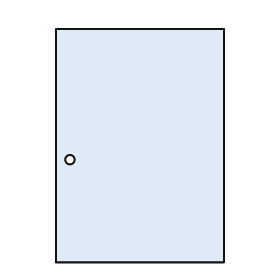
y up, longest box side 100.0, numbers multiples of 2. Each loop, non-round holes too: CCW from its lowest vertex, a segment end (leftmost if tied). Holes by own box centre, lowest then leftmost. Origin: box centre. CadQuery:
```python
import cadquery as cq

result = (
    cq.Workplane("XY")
    .moveTo(-36.0, -50.0)
    .lineTo(36.0, -50.0)
    .lineTo(36.0, 50.0)
    .lineTo(-36.0, 50.0)
    .close()
    .moveTo(-30.0, -6.0)
    .circle(2.0)
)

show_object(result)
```